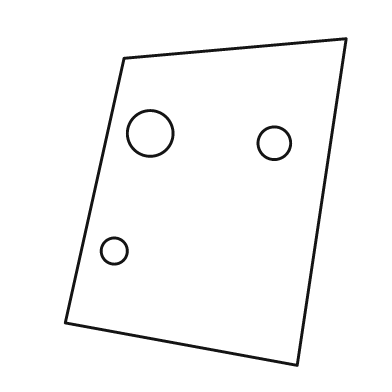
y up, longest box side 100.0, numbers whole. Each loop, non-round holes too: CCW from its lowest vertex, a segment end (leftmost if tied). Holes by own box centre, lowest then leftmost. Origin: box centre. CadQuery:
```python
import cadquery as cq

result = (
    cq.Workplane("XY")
    .moveTo(28.0, -50.0)
    .lineTo(43.0, 50.0)
    .lineTo(-25.0, 44.0)
    .lineTo(-43.0, -37.0)
    .close()
    .moveTo(-28.0, -15.0)
    .circle(4.0)
    .moveTo(21.0, 18.0)
    .circle(5.0)
    .moveTo(-17.0, 21.0)
    .circle(7.0)
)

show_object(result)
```